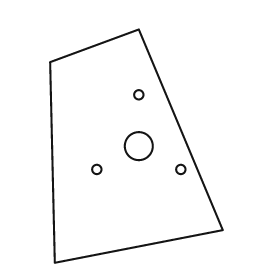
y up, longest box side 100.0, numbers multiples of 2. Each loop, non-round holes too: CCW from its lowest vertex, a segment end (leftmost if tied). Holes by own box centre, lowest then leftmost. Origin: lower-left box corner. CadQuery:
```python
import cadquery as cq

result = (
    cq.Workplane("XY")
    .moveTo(2.0, 0.0)
    .lineTo(74.0, 14.0)
    .lineTo(38.0, 100.0)
    .lineTo(0.0, 86.0)
    .close()
    .moveTo(20.0, 40.0)
    .circle(2.0)
    .moveTo(56.0, 40.0)
    .circle(2.0)
    .moveTo(38.0, 50.0)
    .circle(6.0)
    .moveTo(38.0, 72.0)
    .circle(2.0)
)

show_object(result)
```